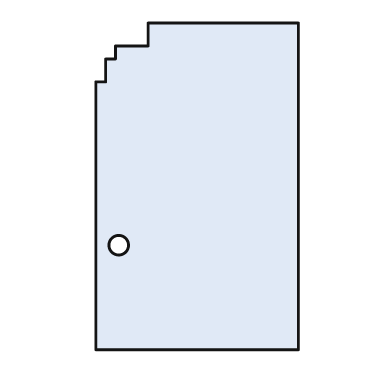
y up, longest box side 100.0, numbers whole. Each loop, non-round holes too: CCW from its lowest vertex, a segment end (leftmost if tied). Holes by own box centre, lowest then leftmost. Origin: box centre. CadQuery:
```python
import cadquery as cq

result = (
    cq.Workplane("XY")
    .moveTo(-31.0, -50.0)
    .lineTo(31.0, -50.0)
    .lineTo(31.0, 50.0)
    .lineTo(-15.0, 50.0)
    .lineTo(-15.0, 43.0)
    .lineTo(-25.0, 43.0)
    .lineTo(-25.0, 39.0)
    .lineTo(-28.0, 39.0)
    .lineTo(-28.0, 32.0)
    .lineTo(-31.0, 32.0)
    .close()
    .moveTo(-24.0, -18.0)
    .circle(3.0)
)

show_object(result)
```